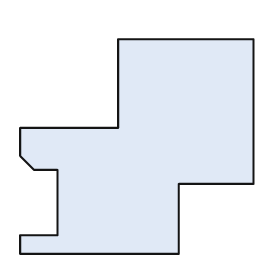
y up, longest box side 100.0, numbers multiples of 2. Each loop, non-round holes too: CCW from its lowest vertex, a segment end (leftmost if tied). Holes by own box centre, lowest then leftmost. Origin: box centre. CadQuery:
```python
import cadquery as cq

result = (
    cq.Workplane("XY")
    .moveTo(-50.0, -46.0)
    .lineTo(18.0, -46.0)
    .lineTo(18.0, -16.0)
    .lineTo(50.0, -16.0)
    .lineTo(50.0, 46.0)
    .lineTo(-8.0, 46.0)
    .lineTo(-8.0, 8.0)
    .lineTo(-50.0, 8.0)
    .lineTo(-50.0, -4.0)
    .lineTo(-44.0, -10.0)
    .lineTo(-34.0, -10.0)
    .lineTo(-34.0, -38.0)
    .lineTo(-50.0, -38.0)
    .close()
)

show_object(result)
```